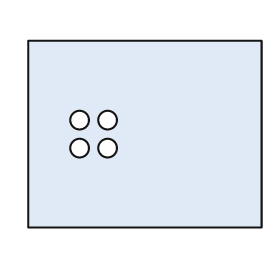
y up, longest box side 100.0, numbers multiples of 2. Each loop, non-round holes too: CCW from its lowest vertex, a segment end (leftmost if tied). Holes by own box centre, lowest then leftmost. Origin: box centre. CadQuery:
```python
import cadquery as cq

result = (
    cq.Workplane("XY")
    .moveTo(-50.0, -40.0)
    .lineTo(50.0, -40.0)
    .lineTo(50.0, 40.0)
    .lineTo(-50.0, 40.0)
    .close()
    .moveTo(-28.0, -6.0)
    .circle(4.0)
    .moveTo(-16.0, -6.0)
    .circle(4.0)
    .moveTo(-28.0, 6.0)
    .circle(4.0)
    .moveTo(-16.0, 6.0)
    .circle(4.0)
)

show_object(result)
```